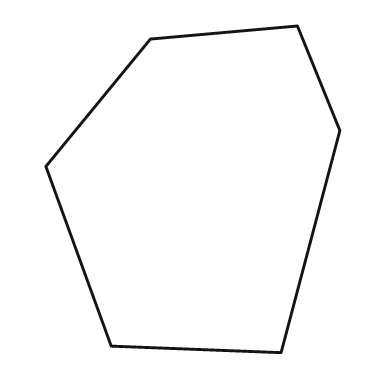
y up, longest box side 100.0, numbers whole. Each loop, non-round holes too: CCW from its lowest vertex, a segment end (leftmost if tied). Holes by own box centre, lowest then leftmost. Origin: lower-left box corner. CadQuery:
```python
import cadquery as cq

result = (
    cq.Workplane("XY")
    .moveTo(72.0, 0.0)
    .lineTo(90.0, 68.0)
    .lineTo(77.0, 100.0)
    .lineTo(32.0, 96.0)
    .lineTo(0.0, 57.0)
    .lineTo(20.0, 2.0)
    .close()
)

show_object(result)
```